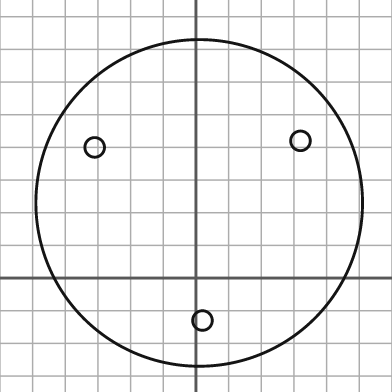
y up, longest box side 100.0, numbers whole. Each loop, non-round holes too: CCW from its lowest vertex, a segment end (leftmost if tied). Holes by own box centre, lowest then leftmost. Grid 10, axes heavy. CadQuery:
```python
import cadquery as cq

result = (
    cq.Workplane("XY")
    .moveTo(1.0, 23.0)
    .circle(50.0)
    .moveTo(2.0, -13.0)
    .circle(3.0)
    .moveTo(-31.0, 40.0)
    .circle(3.0)
    .moveTo(32.0, 42.0)
    .circle(3.0)
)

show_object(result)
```